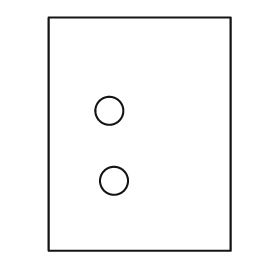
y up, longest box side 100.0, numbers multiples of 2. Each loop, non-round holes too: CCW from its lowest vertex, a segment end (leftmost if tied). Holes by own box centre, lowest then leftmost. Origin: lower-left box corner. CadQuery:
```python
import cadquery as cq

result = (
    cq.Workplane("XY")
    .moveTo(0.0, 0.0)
    .lineTo(78.0, 0.0)
    .lineTo(78.0, 100.0)
    .lineTo(0.0, 100.0)
    .close()
    .moveTo(28.0, 30.0)
    .circle(6.0)
    .moveTo(26.0, 60.0)
    .circle(6.0)
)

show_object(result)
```